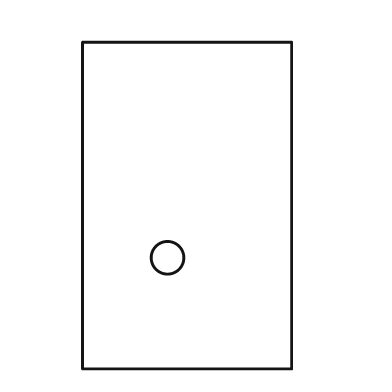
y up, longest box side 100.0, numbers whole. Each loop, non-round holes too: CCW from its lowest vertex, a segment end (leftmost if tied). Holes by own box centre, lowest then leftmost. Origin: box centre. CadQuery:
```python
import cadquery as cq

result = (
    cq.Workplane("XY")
    .moveTo(-32.0, -50.0)
    .lineTo(32.0, -50.0)
    .lineTo(32.0, 50.0)
    .lineTo(-32.0, 50.0)
    .close()
    .moveTo(-6.0, -16.0)
    .circle(5.0)
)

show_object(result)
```